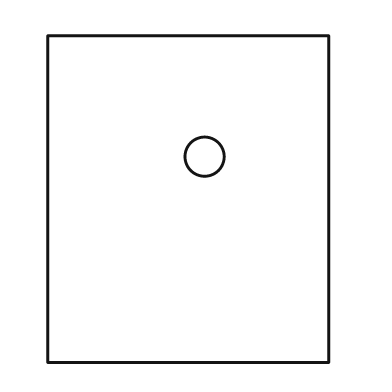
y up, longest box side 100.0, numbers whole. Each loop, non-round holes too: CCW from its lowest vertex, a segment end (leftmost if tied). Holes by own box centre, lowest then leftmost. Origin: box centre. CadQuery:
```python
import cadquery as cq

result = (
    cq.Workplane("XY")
    .moveTo(-43.0, -50.0)
    .lineTo(43.0, -50.0)
    .lineTo(43.0, 50.0)
    .lineTo(-43.0, 50.0)
    .close()
    .moveTo(5.0, 13.0)
    .circle(6.0)
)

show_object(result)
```